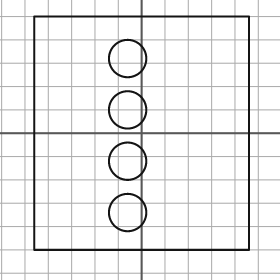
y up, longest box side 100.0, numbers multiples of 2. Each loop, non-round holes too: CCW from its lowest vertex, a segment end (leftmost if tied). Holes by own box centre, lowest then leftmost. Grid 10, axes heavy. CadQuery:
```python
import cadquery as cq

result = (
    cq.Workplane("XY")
    .moveTo(-46.0, -50.0)
    .lineTo(46.0, -50.0)
    .lineTo(46.0, 50.0)
    .lineTo(-46.0, 50.0)
    .close()
    .moveTo(-6.0, -34.0)
    .circle(8.0)
    .moveTo(-6.0, -12.0)
    .circle(8.0)
    .moveTo(-6.0, 10.0)
    .circle(8.0)
    .moveTo(-6.0, 32.0)
    .circle(8.0)
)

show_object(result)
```